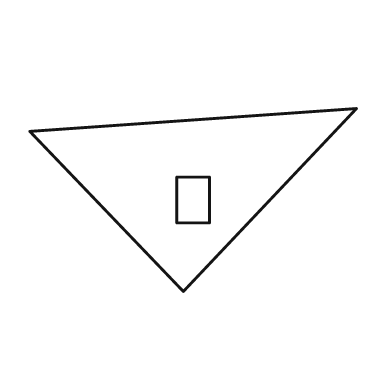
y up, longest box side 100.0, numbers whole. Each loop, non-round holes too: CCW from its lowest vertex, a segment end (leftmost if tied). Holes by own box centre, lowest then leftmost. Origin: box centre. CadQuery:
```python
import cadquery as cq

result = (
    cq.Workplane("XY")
    .moveTo(-3.0, -28.0)
    .lineTo(50.0, 28.0)
    .lineTo(-50.0, 21.0)
    .close()
    .moveTo(-5.0, -7.0)
    .lineTo(5.0, -7.0)
    .lineTo(5.0, 7.0)
    .lineTo(-5.0, 7.0)
    .close()
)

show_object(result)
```